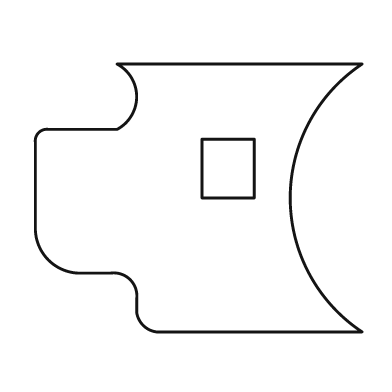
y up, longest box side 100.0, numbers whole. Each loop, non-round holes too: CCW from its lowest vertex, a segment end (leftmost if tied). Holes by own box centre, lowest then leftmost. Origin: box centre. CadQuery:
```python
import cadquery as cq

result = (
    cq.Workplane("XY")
    .moveTo(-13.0, -41.0)
    .lineTo(50.0, -41.0)
    .threePointArc((28.0, 0.0), (50.0, 41.0))
    .lineTo(-25.0, 41.0)
    .threePointArc((-19.0, 31.0), (-25.0, 21.0))
    .lineTo(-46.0, 21.0)
    .threePointArc((-49.0, 20.0), (-50.0, 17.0))
    .lineTo(-50.0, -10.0)
    .threePointArc((-46.0, -19.0), (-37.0, -23.0))
    .lineTo(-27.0, -23.0)
    .threePointArc((-21.0, -25.0), (-19.0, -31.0))
    .lineTo(-19.0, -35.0)
    .threePointArc((-17.0, -39.0), (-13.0, -41.0))
    .close()
    .moveTo(1.0, 0.0)
    .lineTo(17.0, 0.0)
    .lineTo(17.0, 18.0)
    .lineTo(1.0, 18.0)
    .close()
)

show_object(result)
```